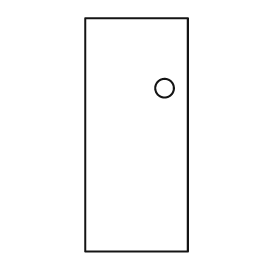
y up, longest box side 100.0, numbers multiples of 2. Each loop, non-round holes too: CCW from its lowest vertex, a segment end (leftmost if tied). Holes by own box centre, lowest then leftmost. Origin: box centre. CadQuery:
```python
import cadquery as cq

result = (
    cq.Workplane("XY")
    .moveTo(-22.0, -50.0)
    .lineTo(22.0, -50.0)
    .lineTo(22.0, 50.0)
    .lineTo(-22.0, 50.0)
    .close()
    .moveTo(12.0, 20.0)
    .circle(4.0)
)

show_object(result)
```